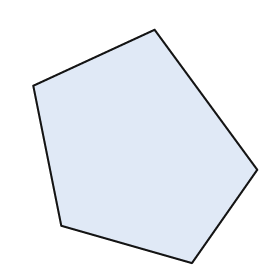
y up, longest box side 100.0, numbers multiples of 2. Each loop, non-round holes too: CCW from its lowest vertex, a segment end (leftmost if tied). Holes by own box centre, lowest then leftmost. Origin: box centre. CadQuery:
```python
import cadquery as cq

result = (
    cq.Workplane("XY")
    .moveTo(20.0, -50.0)
    .lineTo(48.0, -10.0)
    .lineTo(4.0, 50.0)
    .lineTo(-48.0, 26.0)
    .lineTo(-36.0, -34.0)
    .close()
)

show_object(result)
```